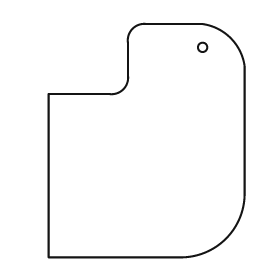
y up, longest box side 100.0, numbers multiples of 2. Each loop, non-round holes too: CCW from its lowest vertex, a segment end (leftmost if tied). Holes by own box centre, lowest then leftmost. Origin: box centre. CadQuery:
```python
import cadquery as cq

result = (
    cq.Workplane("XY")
    .moveTo(-42.0, -50.0)
    .lineTo(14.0, -50.0)
    .threePointArc((34.0, -42.0), (42.0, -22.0))
    .lineTo(42.0, 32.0)
    .threePointArc((36.0, 44.0), (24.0, 50.0))
    .lineTo(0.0, 50.0)
    .threePointArc((-6.0, 48.0), (-8.0, 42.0))
    .lineTo(-8.0, 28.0)
    .threePointArc((-10.0, 22.0), (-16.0, 20.0))
    .lineTo(-42.0, 20.0)
    .close()
    .moveTo(24.0, 40.0)
    .circle(2.0)
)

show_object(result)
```